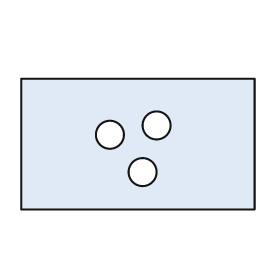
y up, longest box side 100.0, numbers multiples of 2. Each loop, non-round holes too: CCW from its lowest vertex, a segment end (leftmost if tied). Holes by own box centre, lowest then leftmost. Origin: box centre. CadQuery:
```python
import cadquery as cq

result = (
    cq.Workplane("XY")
    .moveTo(-50.0, -28.0)
    .lineTo(50.0, -28.0)
    .lineTo(50.0, 28.0)
    .lineTo(-50.0, 28.0)
    .close()
    .moveTo(2.0, -12.0)
    .circle(6.0)
    .moveTo(-12.0, 4.0)
    .circle(6.0)
    .moveTo(8.0, 8.0)
    .circle(6.0)
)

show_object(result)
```